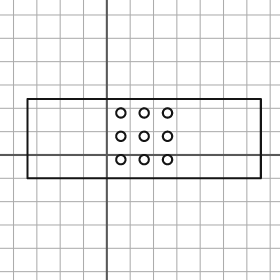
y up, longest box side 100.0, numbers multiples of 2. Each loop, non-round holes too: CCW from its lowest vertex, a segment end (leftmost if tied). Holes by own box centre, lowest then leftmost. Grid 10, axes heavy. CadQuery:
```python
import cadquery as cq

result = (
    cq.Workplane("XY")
    .moveTo(-34.0, -10.0)
    .lineTo(66.0, -10.0)
    .lineTo(66.0, 24.0)
    .lineTo(-34.0, 24.0)
    .close()
    .moveTo(6.0, -2.0)
    .circle(2.0)
    .moveTo(16.0, -2.0)
    .circle(2.0)
    .moveTo(26.0, -2.0)
    .circle(2.0)
    .moveTo(6.0, 8.0)
    .circle(2.0)
    .moveTo(16.0, 8.0)
    .circle(2.0)
    .moveTo(26.0, 8.0)
    .circle(2.0)
    .moveTo(6.0, 18.0)
    .circle(2.0)
    .moveTo(16.0, 18.0)
    .circle(2.0)
    .moveTo(26.0, 18.0)
    .circle(2.0)
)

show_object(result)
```